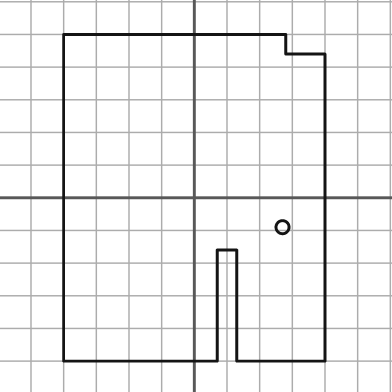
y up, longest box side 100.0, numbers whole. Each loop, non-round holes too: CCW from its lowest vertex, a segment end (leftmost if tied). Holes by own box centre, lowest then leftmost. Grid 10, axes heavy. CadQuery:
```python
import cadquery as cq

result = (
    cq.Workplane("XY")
    .moveTo(-40.0, -50.0)
    .lineTo(7.0, -50.0)
    .lineTo(7.0, -16.0)
    .lineTo(13.0, -16.0)
    .lineTo(13.0, -50.0)
    .lineTo(40.0, -50.0)
    .lineTo(40.0, 44.0)
    .lineTo(28.0, 44.0)
    .lineTo(28.0, 50.0)
    .lineTo(-40.0, 50.0)
    .close()
    .moveTo(27.0, -9.0)
    .circle(2.0)
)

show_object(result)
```